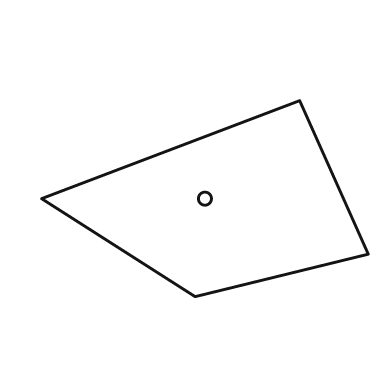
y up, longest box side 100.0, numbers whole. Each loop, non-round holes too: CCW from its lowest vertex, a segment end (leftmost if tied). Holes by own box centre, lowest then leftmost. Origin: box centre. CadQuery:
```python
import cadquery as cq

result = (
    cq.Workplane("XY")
    .moveTo(-3.0, -30.0)
    .lineTo(50.0, -17.0)
    .lineTo(29.0, 30.0)
    .lineTo(-50.0, 0.0)
    .close()
    .moveTo(0.0, 0.0)
    .circle(2.0)
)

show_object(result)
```